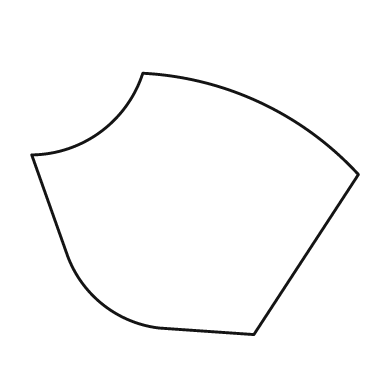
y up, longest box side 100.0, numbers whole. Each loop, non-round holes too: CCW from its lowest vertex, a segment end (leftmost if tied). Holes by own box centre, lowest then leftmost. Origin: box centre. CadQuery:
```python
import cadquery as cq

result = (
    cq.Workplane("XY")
    .moveTo(18.0, -40.0)
    .lineTo(50.0, 9.0)
    .threePointArc((20.0, 31.0), (-16.0, 40.0))
    .threePointArc((-29.0, 22.0), (-50.0, 15.0))
    .lineTo(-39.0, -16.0)
    .threePointArc((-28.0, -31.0), (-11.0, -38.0))
    .close()
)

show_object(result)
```